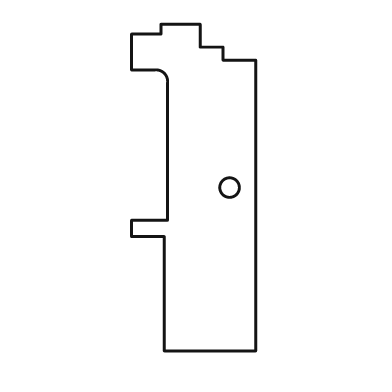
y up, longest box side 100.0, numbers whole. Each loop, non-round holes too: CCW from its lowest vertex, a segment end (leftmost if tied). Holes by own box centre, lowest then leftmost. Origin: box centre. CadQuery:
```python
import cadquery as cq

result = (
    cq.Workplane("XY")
    .moveTo(-9.0, -50.0)
    .lineTo(19.0, -50.0)
    .lineTo(19.0, 39.0)
    .lineTo(9.0, 39.0)
    .lineTo(9.0, 43.0)
    .lineTo(2.0, 43.0)
    .lineTo(2.0, 50.0)
    .lineTo(-10.0, 50.0)
    .lineTo(-10.0, 47.0)
    .lineTo(-19.0, 47.0)
    .lineTo(-19.0, 36.0)
    .lineTo(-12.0, 36.0)
    .threePointArc((-9.0, 35.0), (-8.0, 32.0))
    .lineTo(-8.0, -10.0)
    .lineTo(-19.0, -10.0)
    .lineTo(-19.0, -15.0)
    .lineTo(-9.0, -15.0)
    .close()
    .moveTo(11.0, 0.0)
    .circle(3.0)
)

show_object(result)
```